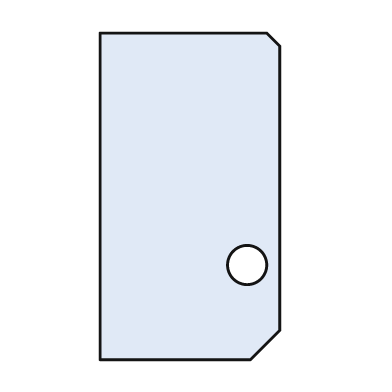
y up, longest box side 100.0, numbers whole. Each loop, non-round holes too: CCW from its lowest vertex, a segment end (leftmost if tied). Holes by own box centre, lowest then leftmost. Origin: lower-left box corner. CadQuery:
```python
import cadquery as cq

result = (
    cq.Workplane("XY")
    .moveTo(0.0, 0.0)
    .lineTo(46.0, 0.0)
    .lineTo(55.0, 9.0)
    .lineTo(55.0, 96.0)
    .lineTo(51.0, 100.0)
    .lineTo(0.0, 100.0)
    .close()
    .moveTo(45.0, 29.0)
    .circle(6.0)
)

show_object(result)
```